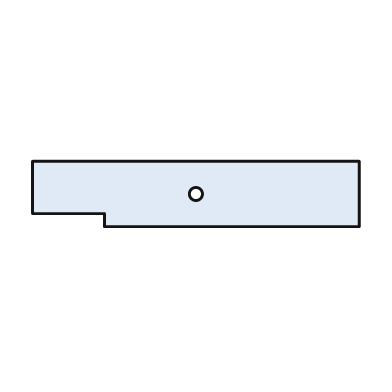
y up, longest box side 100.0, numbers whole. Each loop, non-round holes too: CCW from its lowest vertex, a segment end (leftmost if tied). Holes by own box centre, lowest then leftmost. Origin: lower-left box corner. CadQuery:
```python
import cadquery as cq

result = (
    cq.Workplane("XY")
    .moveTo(22.0, 0.0)
    .lineTo(100.0, 0.0)
    .lineTo(100.0, 20.0)
    .lineTo(0.0, 20.0)
    .lineTo(0.0, 4.0)
    .lineTo(22.0, 4.0)
    .close()
    .moveTo(50.0, 10.0)
    .circle(2.0)
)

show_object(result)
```